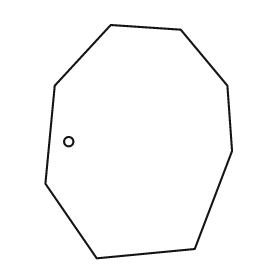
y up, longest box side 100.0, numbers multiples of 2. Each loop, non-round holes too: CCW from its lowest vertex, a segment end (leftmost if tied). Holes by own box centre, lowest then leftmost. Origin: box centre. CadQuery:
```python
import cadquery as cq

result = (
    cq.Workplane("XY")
    .moveTo(-18.0, -50.0)
    .lineTo(24.0, -46.0)
    .lineTo(40.0, -4.0)
    .lineTo(38.0, 24.0)
    .lineTo(18.0, 48.0)
    .lineTo(-12.0, 50.0)
    .lineTo(-36.0, 24.0)
    .lineTo(-40.0, -18.0)
    .close()
    .moveTo(-30.0, 0.0)
    .circle(2.0)
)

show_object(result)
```